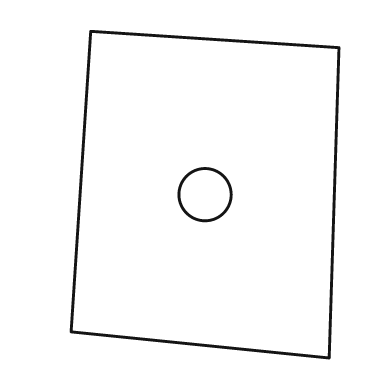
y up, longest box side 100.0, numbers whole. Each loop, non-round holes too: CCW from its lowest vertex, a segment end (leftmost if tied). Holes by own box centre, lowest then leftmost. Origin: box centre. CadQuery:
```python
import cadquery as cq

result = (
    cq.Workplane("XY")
    .moveTo(38.0, -50.0)
    .lineTo(41.0, 45.0)
    .lineTo(-35.0, 50.0)
    .lineTo(-41.0, -42.0)
    .close()
    .moveTo(0.0, 0.0)
    .circle(8.0)
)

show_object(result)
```